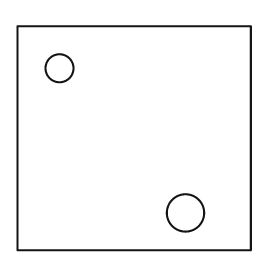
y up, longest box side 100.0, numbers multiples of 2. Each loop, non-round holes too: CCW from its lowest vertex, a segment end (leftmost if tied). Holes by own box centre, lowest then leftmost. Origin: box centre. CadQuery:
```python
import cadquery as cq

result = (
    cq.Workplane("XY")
    .moveTo(-50.0, -48.0)
    .lineTo(50.0, -48.0)
    .lineTo(50.0, 48.0)
    .lineTo(-50.0, 48.0)
    .close()
    .moveTo(22.0, -32.0)
    .circle(8.0)
    .moveTo(-32.0, 30.0)
    .circle(6.0)
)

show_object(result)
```